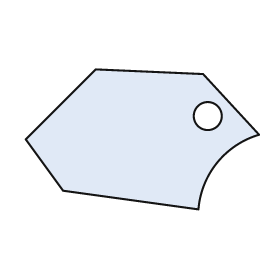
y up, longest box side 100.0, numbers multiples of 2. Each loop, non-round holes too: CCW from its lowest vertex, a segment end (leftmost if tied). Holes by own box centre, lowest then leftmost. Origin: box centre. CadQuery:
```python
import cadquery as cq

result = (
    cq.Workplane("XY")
    .moveTo(24.0, -30.0)
    .threePointArc((32.0, -10.0), (50.0, 2.0))
    .lineTo(26.0, 28.0)
    .lineTo(-20.0, 30.0)
    .lineTo(-50.0, 0.0)
    .lineTo(-34.0, -22.0)
    .close()
    .moveTo(28.0, 10.0)
    .circle(6.0)
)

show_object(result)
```